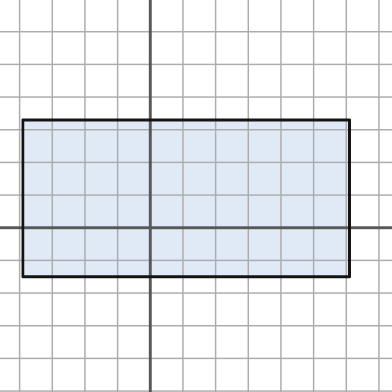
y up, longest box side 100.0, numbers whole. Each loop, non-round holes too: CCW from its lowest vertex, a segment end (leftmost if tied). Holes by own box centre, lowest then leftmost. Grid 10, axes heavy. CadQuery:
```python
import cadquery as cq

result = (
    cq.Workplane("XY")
    .moveTo(-39.0, -15.0)
    .lineTo(61.0, -15.0)
    .lineTo(61.0, 33.0)
    .lineTo(-39.0, 33.0)
    .close()
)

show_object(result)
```